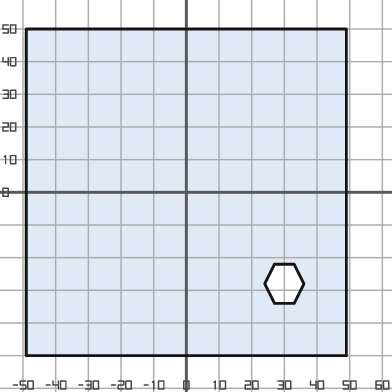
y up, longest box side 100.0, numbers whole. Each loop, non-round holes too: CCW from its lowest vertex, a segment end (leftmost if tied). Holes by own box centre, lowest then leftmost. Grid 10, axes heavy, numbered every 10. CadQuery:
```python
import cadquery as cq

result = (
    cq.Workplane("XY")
    .moveTo(-49.0, -50.0)
    .lineTo(49.0, -50.0)
    .lineTo(49.0, 50.0)
    .lineTo(-49.0, 50.0)
    .close()
    .moveTo(27.0, -34.0)
    .lineTo(33.0, -34.0)
    .lineTo(36.0, -28.0)
    .lineTo(33.0, -22.0)
    .lineTo(27.0, -22.0)
    .lineTo(24.0, -28.0)
    .close()
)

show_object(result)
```